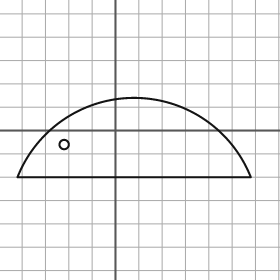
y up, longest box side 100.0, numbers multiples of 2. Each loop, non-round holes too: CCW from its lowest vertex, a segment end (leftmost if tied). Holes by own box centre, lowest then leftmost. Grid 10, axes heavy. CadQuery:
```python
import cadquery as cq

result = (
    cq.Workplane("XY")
    .moveTo(-42.0, -20.0)
    .lineTo(58.0, -20.0)
    .threePointArc((8.0, 14.0), (-42.0, -20.0))
    .close()
    .moveTo(-22.0, -6.0)
    .circle(2.0)
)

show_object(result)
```